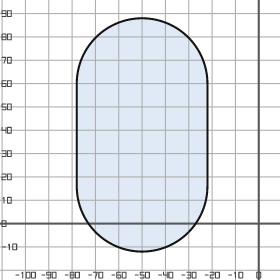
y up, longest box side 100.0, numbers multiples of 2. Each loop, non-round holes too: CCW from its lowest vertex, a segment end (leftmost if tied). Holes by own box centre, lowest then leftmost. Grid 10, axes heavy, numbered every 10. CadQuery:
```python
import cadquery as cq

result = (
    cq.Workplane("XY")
    .moveTo(-78.0, 16.0)
    .threePointArc((-50.0, -12.0), (-22.0, 16.0))
    .lineTo(-22.0, 60.0)
    .threePointArc((-50.0, 88.0), (-78.0, 60.0))
    .close()
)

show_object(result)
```